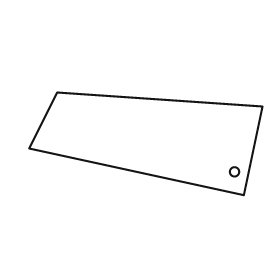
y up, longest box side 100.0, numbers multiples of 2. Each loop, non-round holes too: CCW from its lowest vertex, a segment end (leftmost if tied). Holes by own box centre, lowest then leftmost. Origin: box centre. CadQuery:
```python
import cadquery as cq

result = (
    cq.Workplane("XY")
    .moveTo(42.0, -22.0)
    .lineTo(50.0, 16.0)
    .lineTo(-38.0, 22.0)
    .lineTo(-50.0, -2.0)
    .close()
    .moveTo(38.0, -12.0)
    .circle(2.0)
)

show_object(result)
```